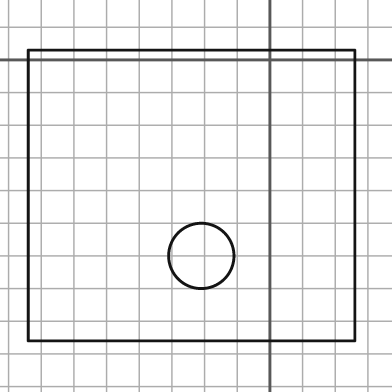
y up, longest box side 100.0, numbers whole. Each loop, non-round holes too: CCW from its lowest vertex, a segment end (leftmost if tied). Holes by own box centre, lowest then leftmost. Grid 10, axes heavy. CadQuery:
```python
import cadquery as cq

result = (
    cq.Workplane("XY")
    .moveTo(-74.0, -86.0)
    .lineTo(26.0, -86.0)
    .lineTo(26.0, 3.0)
    .lineTo(-74.0, 3.0)
    .close()
    .moveTo(-21.0, -60.0)
    .circle(10.0)
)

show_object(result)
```